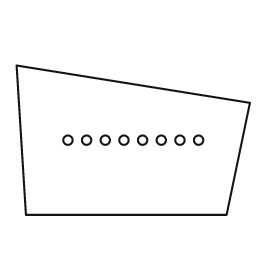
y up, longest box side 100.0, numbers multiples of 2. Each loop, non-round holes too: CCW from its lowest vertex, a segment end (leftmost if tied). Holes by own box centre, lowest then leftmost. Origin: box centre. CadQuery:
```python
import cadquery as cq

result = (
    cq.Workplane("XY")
    .moveTo(-46.0, -32.0)
    .lineTo(40.0, -32.0)
    .lineTo(50.0, 16.0)
    .lineTo(-50.0, 32.0)
    .close()
    .moveTo(-28.0, 0.0)
    .circle(2.0)
    .moveTo(-20.0, 0.0)
    .circle(2.0)
    .moveTo(-12.0, 0.0)
    .circle(2.0)
    .moveTo(-4.0, 0.0)
    .circle(2.0)
    .moveTo(4.0, 0.0)
    .circle(2.0)
    .moveTo(12.0, 0.0)
    .circle(2.0)
    .moveTo(20.0, 0.0)
    .circle(2.0)
    .moveTo(28.0, 0.0)
    .circle(2.0)
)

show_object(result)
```